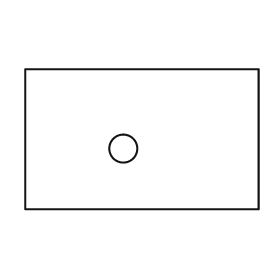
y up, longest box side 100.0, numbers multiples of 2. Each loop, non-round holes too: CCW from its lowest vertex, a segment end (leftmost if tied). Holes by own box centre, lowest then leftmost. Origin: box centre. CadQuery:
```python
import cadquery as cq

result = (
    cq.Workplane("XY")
    .moveTo(-50.0, -30.0)
    .lineTo(50.0, -30.0)
    .lineTo(50.0, 30.0)
    .lineTo(-50.0, 30.0)
    .close()
    .moveTo(-8.0, -4.0)
    .circle(6.0)
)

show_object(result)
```